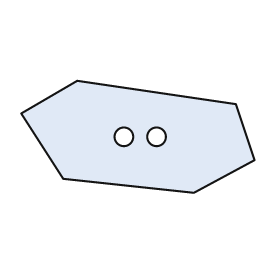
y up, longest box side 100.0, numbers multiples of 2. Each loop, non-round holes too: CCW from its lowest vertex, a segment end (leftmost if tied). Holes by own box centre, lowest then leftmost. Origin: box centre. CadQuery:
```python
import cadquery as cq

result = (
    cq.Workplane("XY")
    .moveTo(24.0, -24.0)
    .lineTo(50.0, -10.0)
    .lineTo(42.0, 14.0)
    .lineTo(-26.0, 24.0)
    .lineTo(-50.0, 10.0)
    .lineTo(-32.0, -18.0)
    .close()
    .moveTo(-6.0, 0.0)
    .circle(4.0)
    .moveTo(8.0, 0.0)
    .circle(4.0)
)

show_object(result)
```